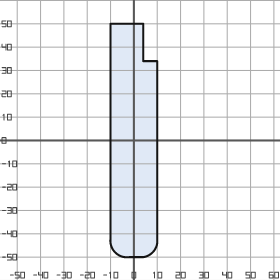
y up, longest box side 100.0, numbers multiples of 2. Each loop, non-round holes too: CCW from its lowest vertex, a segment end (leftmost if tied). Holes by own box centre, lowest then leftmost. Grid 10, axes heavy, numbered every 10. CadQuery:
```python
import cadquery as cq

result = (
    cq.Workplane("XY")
    .moveTo(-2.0, -50.0)
    .lineTo(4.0, -50.0)
    .threePointArc((8.0, -48.0), (10.0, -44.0))
    .lineTo(10.0, 34.0)
    .lineTo(4.0, 34.0)
    .lineTo(4.0, 50.0)
    .lineTo(-10.0, 50.0)
    .lineTo(-10.0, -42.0)
    .threePointArc((-8.0, -48.0), (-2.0, -50.0))
    .close()
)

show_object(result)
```